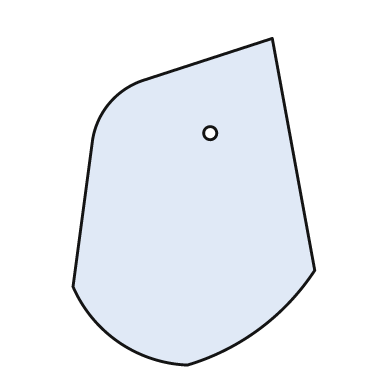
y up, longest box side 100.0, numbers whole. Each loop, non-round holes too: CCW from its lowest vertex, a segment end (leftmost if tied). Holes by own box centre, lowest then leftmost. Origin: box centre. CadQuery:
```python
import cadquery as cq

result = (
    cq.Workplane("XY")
    .moveTo(-2.0, -50.0)
    .threePointArc((20.0, -39.0), (37.0, -21.0))
    .lineTo(24.0, 50.0)
    .lineTo(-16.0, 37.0)
    .threePointArc((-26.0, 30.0), (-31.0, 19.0))
    .lineTo(-37.0, -26.0)
    .threePointArc((-23.0, -43.0), (-2.0, -50.0))
    .close()
    .moveTo(5.0, 21.0)
    .circle(2.0)
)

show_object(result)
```